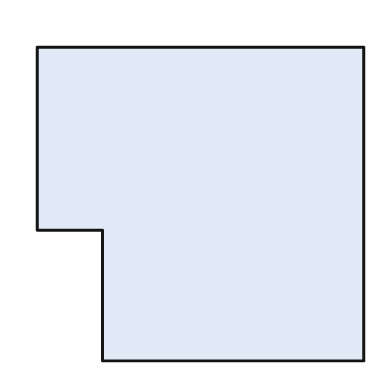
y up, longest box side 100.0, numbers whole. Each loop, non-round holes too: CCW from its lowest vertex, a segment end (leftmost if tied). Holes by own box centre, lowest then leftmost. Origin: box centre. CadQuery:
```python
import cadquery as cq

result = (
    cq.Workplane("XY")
    .moveTo(-30.0, -48.0)
    .lineTo(50.0, -48.0)
    .lineTo(50.0, 48.0)
    .lineTo(-50.0, 48.0)
    .lineTo(-50.0, -8.0)
    .lineTo(-30.0, -8.0)
    .close()
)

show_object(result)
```